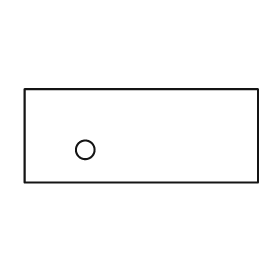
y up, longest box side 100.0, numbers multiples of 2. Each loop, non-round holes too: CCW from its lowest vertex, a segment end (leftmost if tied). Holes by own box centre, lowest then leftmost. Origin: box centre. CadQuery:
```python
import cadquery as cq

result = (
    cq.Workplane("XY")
    .moveTo(-50.0, -20.0)
    .lineTo(50.0, -20.0)
    .lineTo(50.0, 20.0)
    .lineTo(-50.0, 20.0)
    .close()
    .moveTo(-24.0, -6.0)
    .circle(4.0)
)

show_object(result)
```